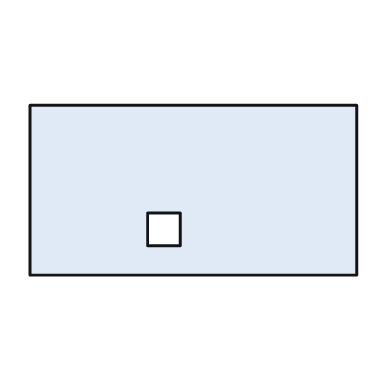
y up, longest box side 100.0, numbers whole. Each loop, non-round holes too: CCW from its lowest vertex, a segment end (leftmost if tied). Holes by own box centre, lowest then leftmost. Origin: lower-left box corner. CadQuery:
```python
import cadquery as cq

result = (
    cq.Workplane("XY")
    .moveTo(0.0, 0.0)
    .lineTo(100.0, 0.0)
    .lineTo(100.0, 52.0)
    .lineTo(0.0, 52.0)
    .close()
    .moveTo(36.0, 9.0)
    .lineTo(46.0, 9.0)
    .lineTo(46.0, 19.0)
    .lineTo(36.0, 19.0)
    .close()
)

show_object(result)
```